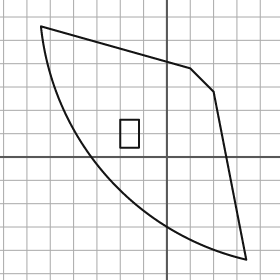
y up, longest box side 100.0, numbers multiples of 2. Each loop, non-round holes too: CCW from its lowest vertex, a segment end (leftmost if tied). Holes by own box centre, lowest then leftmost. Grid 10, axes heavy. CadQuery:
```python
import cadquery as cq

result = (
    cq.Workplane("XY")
    .moveTo(34.0, -44.0)
    .lineTo(20.0, 28.0)
    .lineTo(10.0, 38.0)
    .lineTo(-54.0, 56.0)
    .threePointArc((-26.0, -8.0), (34.0, -44.0))
    .close()
    .moveTo(-20.0, 4.0)
    .lineTo(-12.0, 4.0)
    .lineTo(-12.0, 16.0)
    .lineTo(-20.0, 16.0)
    .close()
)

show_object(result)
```